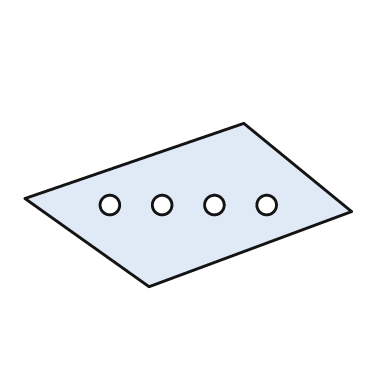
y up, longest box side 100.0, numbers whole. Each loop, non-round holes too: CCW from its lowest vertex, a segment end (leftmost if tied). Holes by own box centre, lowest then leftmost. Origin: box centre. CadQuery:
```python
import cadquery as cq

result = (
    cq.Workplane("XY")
    .moveTo(-12.0, -25.0)
    .lineTo(50.0, -2.0)
    .lineTo(17.0, 25.0)
    .lineTo(-50.0, 2.0)
    .close()
    .moveTo(-24.0, 0.0)
    .circle(3.0)
    .moveTo(-8.0, 0.0)
    .circle(3.0)
    .moveTo(8.0, 0.0)
    .circle(3.0)
    .moveTo(24.0, 0.0)
    .circle(3.0)
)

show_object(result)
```